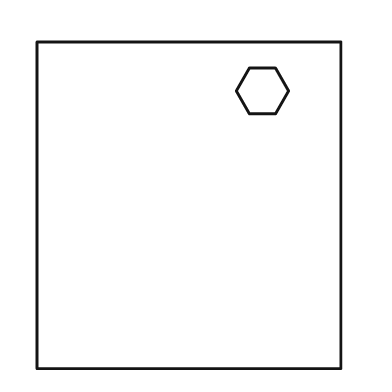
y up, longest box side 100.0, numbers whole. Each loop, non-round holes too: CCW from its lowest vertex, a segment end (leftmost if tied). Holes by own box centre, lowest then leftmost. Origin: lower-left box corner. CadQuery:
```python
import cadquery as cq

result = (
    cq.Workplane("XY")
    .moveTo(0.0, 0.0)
    .lineTo(93.0, 0.0)
    .lineTo(93.0, 100.0)
    .lineTo(0.0, 100.0)
    .close()
    .moveTo(65.0, 78.0)
    .lineTo(73.0, 78.0)
    .lineTo(77.0, 85.0)
    .lineTo(73.0, 92.0)
    .lineTo(65.0, 92.0)
    .lineTo(61.0, 85.0)
    .close()
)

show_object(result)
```